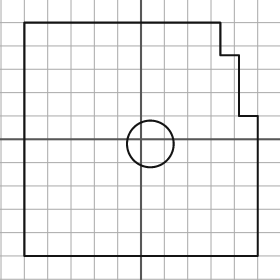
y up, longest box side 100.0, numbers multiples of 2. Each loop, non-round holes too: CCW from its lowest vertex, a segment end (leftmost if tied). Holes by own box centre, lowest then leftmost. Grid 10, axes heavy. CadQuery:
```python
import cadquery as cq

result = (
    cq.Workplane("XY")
    .moveTo(-50.0, -50.0)
    .lineTo(50.0, -50.0)
    .lineTo(50.0, 10.0)
    .lineTo(42.0, 10.0)
    .lineTo(42.0, 36.0)
    .lineTo(34.0, 36.0)
    .lineTo(34.0, 50.0)
    .lineTo(-50.0, 50.0)
    .close()
    .moveTo(4.0, -2.0)
    .circle(10.0)
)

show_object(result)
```